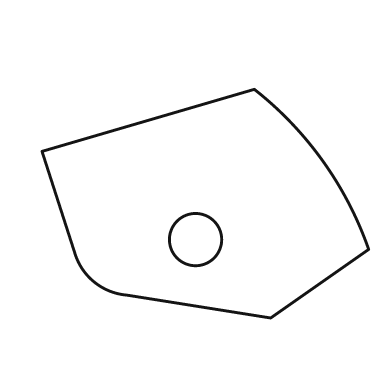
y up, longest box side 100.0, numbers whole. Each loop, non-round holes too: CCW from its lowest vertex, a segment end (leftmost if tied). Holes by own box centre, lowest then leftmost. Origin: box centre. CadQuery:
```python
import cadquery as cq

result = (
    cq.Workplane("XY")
    .moveTo(20.0, -35.0)
    .lineTo(50.0, -14.0)
    .threePointArc((36.0, 13.0), (15.0, 35.0))
    .lineTo(-50.0, 16.0)
    .lineTo(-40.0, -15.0)
    .threePointArc((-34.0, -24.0), (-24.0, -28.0))
    .close()
    .moveTo(-3.0, -11.0)
    .circle(8.0)
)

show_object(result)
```